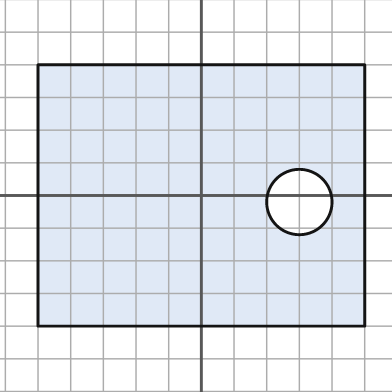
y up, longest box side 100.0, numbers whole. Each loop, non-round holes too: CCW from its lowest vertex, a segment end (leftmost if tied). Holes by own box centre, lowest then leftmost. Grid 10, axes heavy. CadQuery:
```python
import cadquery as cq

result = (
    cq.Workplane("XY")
    .moveTo(-50.0, -40.0)
    .lineTo(50.0, -40.0)
    .lineTo(50.0, 40.0)
    .lineTo(-50.0, 40.0)
    .close()
    .moveTo(30.0, -2.0)
    .circle(10.0)
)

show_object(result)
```